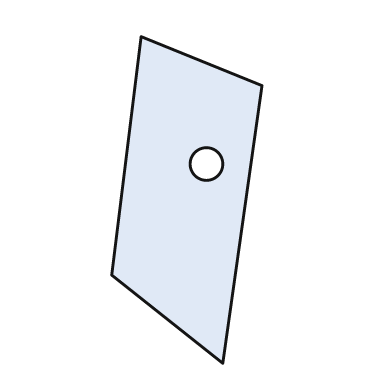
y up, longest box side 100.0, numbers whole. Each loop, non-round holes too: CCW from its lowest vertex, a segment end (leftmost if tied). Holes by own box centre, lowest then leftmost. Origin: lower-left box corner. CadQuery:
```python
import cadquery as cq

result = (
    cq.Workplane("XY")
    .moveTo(34.0, 0.0)
    .lineTo(46.0, 85.0)
    .lineTo(9.0, 100.0)
    .lineTo(0.0, 27.0)
    .close()
    .moveTo(29.0, 61.0)
    .circle(5.0)
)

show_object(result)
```